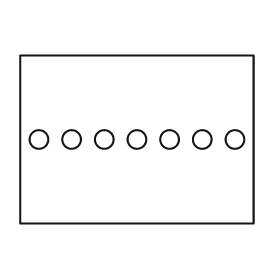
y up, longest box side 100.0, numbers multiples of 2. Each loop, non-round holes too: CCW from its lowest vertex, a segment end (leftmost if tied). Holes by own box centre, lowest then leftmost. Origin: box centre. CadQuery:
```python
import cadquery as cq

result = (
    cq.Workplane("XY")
    .moveTo(-50.0, -36.0)
    .lineTo(50.0, -36.0)
    .lineTo(50.0, 36.0)
    .lineTo(-50.0, 36.0)
    .close()
    .moveTo(-42.0, 0.0)
    .circle(4.0)
    .moveTo(-28.0, 0.0)
    .circle(4.0)
    .moveTo(-14.0, 0.0)
    .circle(4.0)
    .moveTo(0.0, 0.0)
    .circle(4.0)
    .moveTo(14.0, 0.0)
    .circle(4.0)
    .moveTo(28.0, 0.0)
    .circle(4.0)
    .moveTo(42.0, 0.0)
    .circle(4.0)
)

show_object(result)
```